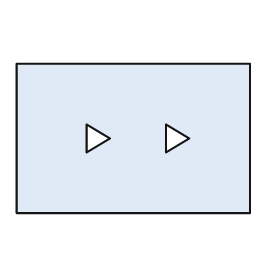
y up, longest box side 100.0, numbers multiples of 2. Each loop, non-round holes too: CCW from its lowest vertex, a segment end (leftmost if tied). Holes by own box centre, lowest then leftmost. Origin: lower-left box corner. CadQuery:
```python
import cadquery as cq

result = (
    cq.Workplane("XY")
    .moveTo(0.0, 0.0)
    .lineTo(100.0, 0.0)
    .lineTo(100.0, 64.0)
    .lineTo(0.0, 64.0)
    .close()
    .moveTo(30.0, 26.0)
    .lineTo(40.0, 32.0)
    .lineTo(30.0, 38.0)
    .close()
    .moveTo(64.0, 26.0)
    .lineTo(74.0, 32.0)
    .lineTo(64.0, 38.0)
    .close()
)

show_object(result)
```